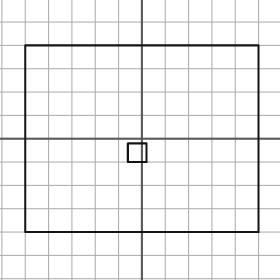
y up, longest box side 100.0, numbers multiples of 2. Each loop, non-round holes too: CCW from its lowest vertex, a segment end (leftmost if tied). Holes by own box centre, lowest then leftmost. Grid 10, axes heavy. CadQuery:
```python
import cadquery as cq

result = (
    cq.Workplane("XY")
    .moveTo(-50.0, -40.0)
    .lineTo(50.0, -40.0)
    .lineTo(50.0, 40.0)
    .lineTo(-50.0, 40.0)
    .close()
    .moveTo(-6.0, -10.0)
    .lineTo(2.0, -10.0)
    .lineTo(2.0, -2.0)
    .lineTo(-6.0, -2.0)
    .close()
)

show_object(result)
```